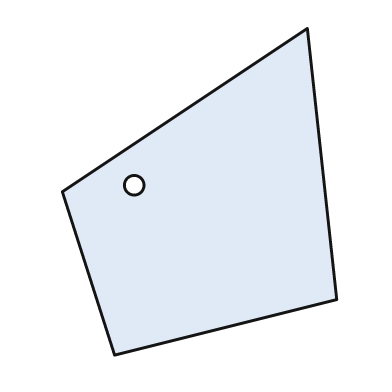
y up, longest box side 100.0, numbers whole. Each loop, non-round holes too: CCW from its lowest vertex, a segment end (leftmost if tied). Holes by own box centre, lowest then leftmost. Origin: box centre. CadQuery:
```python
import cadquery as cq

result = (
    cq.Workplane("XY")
    .moveTo(-26.0, -50.0)
    .lineTo(42.0, -33.0)
    .lineTo(33.0, 50.0)
    .lineTo(-42.0, 0.0)
    .close()
    .moveTo(-20.0, 2.0)
    .circle(3.0)
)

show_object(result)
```